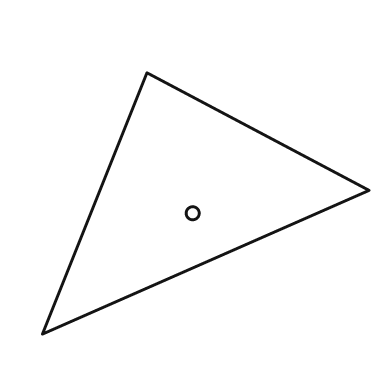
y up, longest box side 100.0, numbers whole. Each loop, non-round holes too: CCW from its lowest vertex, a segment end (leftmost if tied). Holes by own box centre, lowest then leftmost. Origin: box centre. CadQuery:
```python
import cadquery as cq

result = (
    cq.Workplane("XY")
    .moveTo(-50.0, -40.0)
    .lineTo(50.0, 4.0)
    .lineTo(-18.0, 40.0)
    .close()
    .moveTo(-4.0, -3.0)
    .circle(2.0)
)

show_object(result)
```